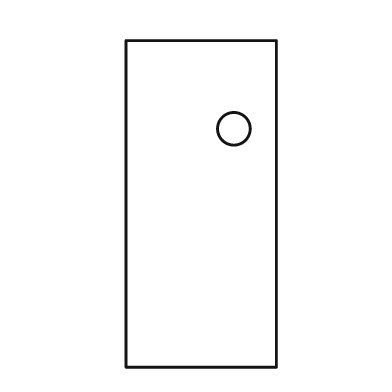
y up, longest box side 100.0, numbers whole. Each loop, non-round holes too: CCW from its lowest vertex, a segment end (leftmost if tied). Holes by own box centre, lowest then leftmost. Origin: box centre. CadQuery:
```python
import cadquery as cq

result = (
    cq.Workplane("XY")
    .moveTo(-23.0, -50.0)
    .lineTo(23.0, -50.0)
    .lineTo(23.0, 50.0)
    .lineTo(-23.0, 50.0)
    .close()
    .moveTo(10.0, 23.0)
    .circle(5.0)
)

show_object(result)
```